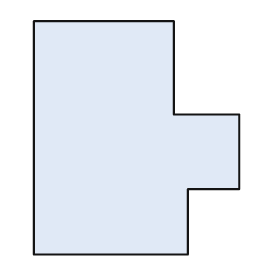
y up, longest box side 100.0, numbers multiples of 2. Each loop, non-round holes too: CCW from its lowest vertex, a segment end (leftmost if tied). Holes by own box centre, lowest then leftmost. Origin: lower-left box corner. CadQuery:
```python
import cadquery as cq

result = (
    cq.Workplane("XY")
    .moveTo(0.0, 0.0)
    .lineTo(66.0, 0.0)
    .lineTo(66.0, 28.0)
    .lineTo(88.0, 28.0)
    .lineTo(88.0, 60.0)
    .lineTo(60.0, 60.0)
    .lineTo(60.0, 100.0)
    .lineTo(0.0, 100.0)
    .close()
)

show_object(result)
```